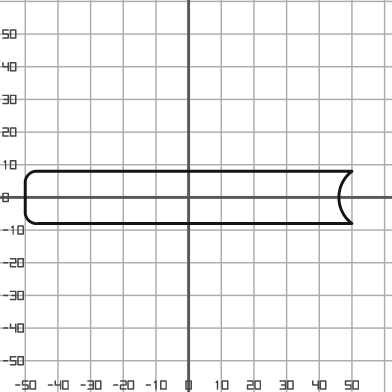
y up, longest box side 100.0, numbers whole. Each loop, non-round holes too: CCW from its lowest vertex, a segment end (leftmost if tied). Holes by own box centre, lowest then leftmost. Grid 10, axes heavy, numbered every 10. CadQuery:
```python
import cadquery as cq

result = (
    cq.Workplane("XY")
    .moveTo(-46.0, -8.0)
    .lineTo(50.0, -8.0)
    .threePointArc((46.0, 0.0), (50.0, 8.0))
    .lineTo(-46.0, 8.0)
    .threePointArc((-49.0, 7.0), (-50.0, 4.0))
    .lineTo(-50.0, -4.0)
    .threePointArc((-49.0, -7.0), (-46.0, -8.0))
    .close()
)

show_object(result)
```